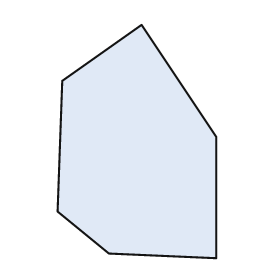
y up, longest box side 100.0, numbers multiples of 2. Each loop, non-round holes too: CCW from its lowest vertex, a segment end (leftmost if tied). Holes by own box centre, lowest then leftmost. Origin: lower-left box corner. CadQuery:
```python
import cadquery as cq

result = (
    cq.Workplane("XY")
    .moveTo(68.0, 0.0)
    .lineTo(68.0, 52.0)
    .lineTo(36.0, 100.0)
    .lineTo(2.0, 76.0)
    .lineTo(0.0, 20.0)
    .lineTo(22.0, 2.0)
    .close()
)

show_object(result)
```